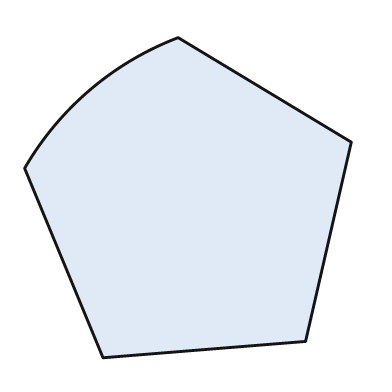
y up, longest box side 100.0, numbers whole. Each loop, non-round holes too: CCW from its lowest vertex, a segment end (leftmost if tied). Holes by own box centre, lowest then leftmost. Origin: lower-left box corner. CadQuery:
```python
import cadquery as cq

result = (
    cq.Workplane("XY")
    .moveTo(24.0, 0.0)
    .lineTo(86.0, 5.0)
    .lineTo(100.0, 66.0)
    .lineTo(47.0, 98.0)
    .threePointArc((20.0, 82.0), (0.0, 58.0))
    .close()
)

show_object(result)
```